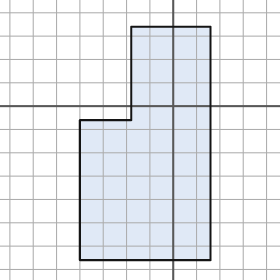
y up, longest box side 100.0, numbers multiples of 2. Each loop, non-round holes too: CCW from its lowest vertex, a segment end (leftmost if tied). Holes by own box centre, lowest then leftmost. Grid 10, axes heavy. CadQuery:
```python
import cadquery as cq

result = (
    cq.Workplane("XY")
    .moveTo(-40.0, -66.0)
    .lineTo(16.0, -66.0)
    .lineTo(16.0, 34.0)
    .lineTo(-18.0, 34.0)
    .lineTo(-18.0, -6.0)
    .lineTo(-40.0, -6.0)
    .close()
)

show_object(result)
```